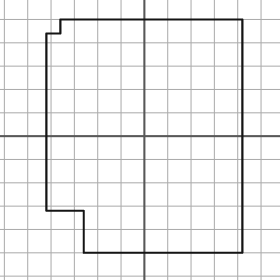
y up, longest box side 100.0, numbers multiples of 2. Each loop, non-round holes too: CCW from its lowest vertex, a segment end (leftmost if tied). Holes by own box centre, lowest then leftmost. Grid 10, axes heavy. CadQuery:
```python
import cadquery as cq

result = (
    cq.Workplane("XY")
    .moveTo(-26.0, -50.0)
    .lineTo(42.0, -50.0)
    .lineTo(42.0, 50.0)
    .lineTo(-36.0, 50.0)
    .lineTo(-36.0, 44.0)
    .lineTo(-42.0, 44.0)
    .lineTo(-42.0, -32.0)
    .lineTo(-26.0, -32.0)
    .close()
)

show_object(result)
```